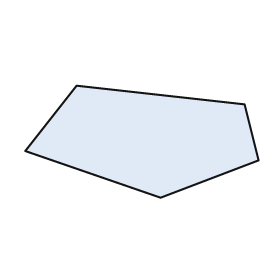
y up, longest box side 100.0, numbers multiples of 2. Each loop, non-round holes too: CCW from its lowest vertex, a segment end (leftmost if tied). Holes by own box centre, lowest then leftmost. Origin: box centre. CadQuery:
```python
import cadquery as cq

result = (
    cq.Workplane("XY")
    .moveTo(8.0, -24.0)
    .lineTo(50.0, -8.0)
    .lineTo(44.0, 16.0)
    .lineTo(-28.0, 24.0)
    .lineTo(-50.0, -4.0)
    .close()
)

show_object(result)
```